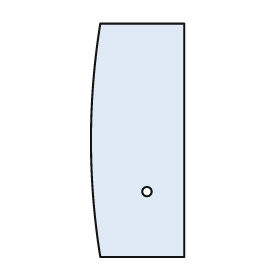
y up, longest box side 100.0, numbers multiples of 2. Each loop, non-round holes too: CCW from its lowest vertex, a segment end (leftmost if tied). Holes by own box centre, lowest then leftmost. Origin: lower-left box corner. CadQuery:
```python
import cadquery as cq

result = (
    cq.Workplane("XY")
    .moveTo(4.0, 0.0)
    .lineTo(40.0, 0.0)
    .lineTo(40.0, 100.0)
    .lineTo(4.0, 100.0)
    .threePointArc((0.0, 50.0), (4.0, 0.0))
    .close()
    .moveTo(24.0, 28.0)
    .circle(2.0)
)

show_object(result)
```